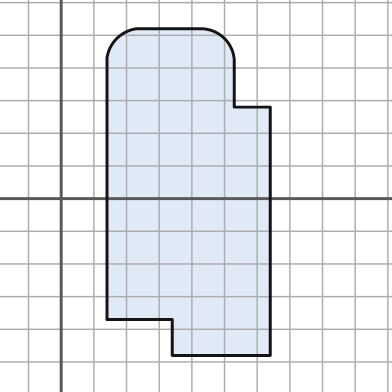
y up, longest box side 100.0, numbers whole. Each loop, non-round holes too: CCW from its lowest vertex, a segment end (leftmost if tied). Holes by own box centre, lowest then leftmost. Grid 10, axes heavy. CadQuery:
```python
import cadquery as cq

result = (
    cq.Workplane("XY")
    .moveTo(34.0, -48.0)
    .lineTo(64.0, -48.0)
    .lineTo(64.0, 28.0)
    .lineTo(53.0, 28.0)
    .lineTo(53.0, 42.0)
    .threePointArc((50.0, 49.0), (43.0, 52.0))
    .lineTo(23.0, 52.0)
    .threePointArc((17.0, 49.0), (14.0, 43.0))
    .lineTo(14.0, -37.0)
    .lineTo(34.0, -37.0)
    .close()
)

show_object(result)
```